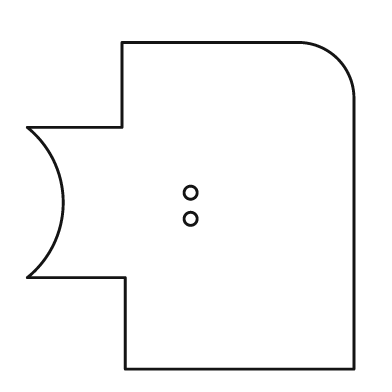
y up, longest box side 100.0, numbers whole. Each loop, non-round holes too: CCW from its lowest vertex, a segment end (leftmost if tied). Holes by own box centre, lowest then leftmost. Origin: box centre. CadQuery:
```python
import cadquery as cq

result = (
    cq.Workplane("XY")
    .moveTo(-20.0, -50.0)
    .lineTo(50.0, -50.0)
    .lineTo(50.0, 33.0)
    .threePointArc((45.0, 45.0), (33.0, 50.0))
    .lineTo(-21.0, 50.0)
    .lineTo(-21.0, 24.0)
    .lineTo(-50.0, 24.0)
    .threePointArc((-39.0, 1.0), (-50.0, -22.0))
    .lineTo(-20.0, -22.0)
    .close()
    .moveTo(0.0, -4.0)
    .circle(2.0)
    .moveTo(0.0, 4.0)
    .circle(2.0)
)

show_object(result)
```